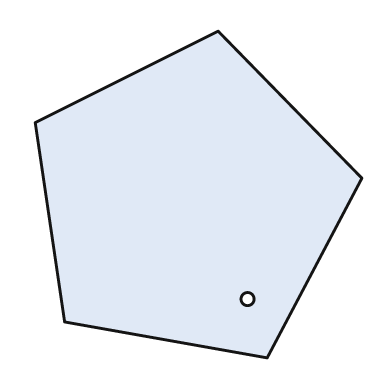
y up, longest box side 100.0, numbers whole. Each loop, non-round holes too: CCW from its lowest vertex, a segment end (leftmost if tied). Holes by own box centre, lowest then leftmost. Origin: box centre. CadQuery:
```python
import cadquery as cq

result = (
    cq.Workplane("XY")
    .moveTo(21.0, -50.0)
    .lineTo(50.0, 5.0)
    .lineTo(6.0, 50.0)
    .lineTo(-50.0, 22.0)
    .lineTo(-41.0, -39.0)
    .close()
    .moveTo(15.0, -32.0)
    .circle(2.0)
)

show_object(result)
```